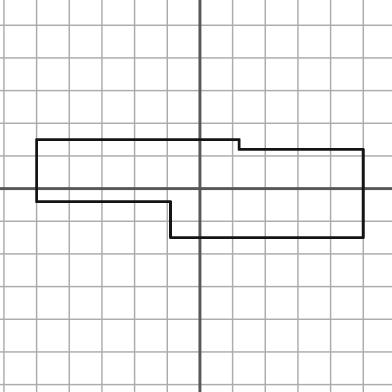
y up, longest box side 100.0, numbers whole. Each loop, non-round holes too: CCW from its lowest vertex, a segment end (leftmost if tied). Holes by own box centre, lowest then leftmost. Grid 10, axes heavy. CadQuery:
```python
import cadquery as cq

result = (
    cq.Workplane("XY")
    .moveTo(-9.0, -15.0)
    .lineTo(50.0, -15.0)
    .lineTo(50.0, 12.0)
    .lineTo(12.0, 12.0)
    .lineTo(12.0, 15.0)
    .lineTo(-50.0, 15.0)
    .lineTo(-50.0, -4.0)
    .lineTo(-9.0, -4.0)
    .close()
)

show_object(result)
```